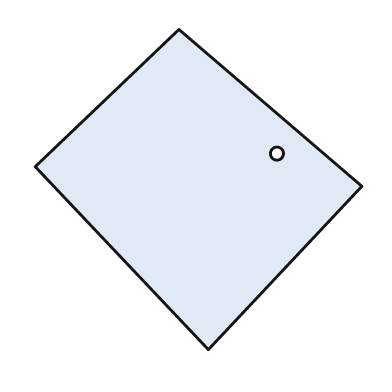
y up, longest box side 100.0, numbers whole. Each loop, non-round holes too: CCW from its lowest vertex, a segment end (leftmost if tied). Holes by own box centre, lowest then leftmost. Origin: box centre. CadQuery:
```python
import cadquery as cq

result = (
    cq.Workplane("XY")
    .moveTo(3.0, -49.0)
    .lineTo(50.0, 1.0)
    .lineTo(-6.0, 49.0)
    .lineTo(-50.0, 7.0)
    .close()
    .moveTo(24.0, 11.0)
    .circle(2.0)
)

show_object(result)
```